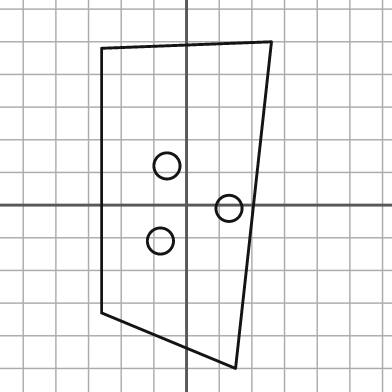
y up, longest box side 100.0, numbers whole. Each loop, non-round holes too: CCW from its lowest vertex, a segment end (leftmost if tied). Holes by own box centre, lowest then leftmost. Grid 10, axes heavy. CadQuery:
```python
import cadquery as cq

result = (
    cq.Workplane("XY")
    .moveTo(15.0, -50.0)
    .lineTo(26.0, 50.0)
    .lineTo(-26.0, 48.0)
    .lineTo(-26.0, -33.0)
    .close()
    .moveTo(-8.0, -11.0)
    .circle(4.0)
    .moveTo(13.0, -1.0)
    .circle(4.0)
    .moveTo(-6.0, 12.0)
    .circle(4.0)
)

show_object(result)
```